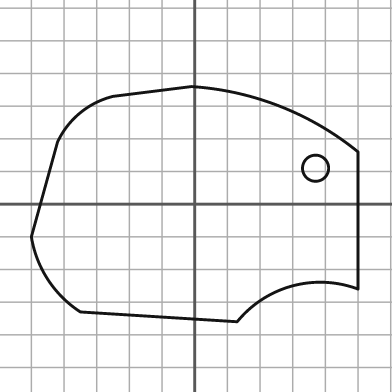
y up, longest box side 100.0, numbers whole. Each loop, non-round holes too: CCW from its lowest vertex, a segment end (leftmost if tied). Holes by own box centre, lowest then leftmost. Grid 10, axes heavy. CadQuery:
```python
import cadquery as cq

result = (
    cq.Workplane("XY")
    .moveTo(13.0, -36.0)
    .threePointArc((30.0, -25.0), (50.0, -26.0))
    .lineTo(50.0, 16.0)
    .threePointArc((26.0, 30.0), (-1.0, 36.0))
    .lineTo(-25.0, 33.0)
    .threePointArc((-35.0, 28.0), (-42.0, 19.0))
    .lineTo(-50.0, -10.0)
    .threePointArc((-45.0, -23.0), (-35.0, -33.0))
    .close()
    .moveTo(37.0, 11.0)
    .circle(4.0)
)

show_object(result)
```